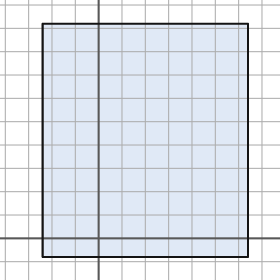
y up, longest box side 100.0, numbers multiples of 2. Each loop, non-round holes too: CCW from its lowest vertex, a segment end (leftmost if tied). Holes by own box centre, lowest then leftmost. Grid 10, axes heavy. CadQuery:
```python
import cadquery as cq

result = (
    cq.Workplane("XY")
    .moveTo(-24.0, -8.0)
    .lineTo(64.0, -8.0)
    .lineTo(64.0, 92.0)
    .lineTo(-24.0, 92.0)
    .close()
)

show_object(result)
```